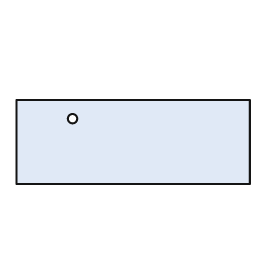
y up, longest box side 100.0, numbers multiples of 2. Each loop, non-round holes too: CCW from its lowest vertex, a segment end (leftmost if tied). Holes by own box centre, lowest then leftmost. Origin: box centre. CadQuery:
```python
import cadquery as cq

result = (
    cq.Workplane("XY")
    .moveTo(-50.0, -18.0)
    .lineTo(50.0, -18.0)
    .lineTo(50.0, 18.0)
    .lineTo(-50.0, 18.0)
    .close()
    .moveTo(-26.0, 10.0)
    .circle(2.0)
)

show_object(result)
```